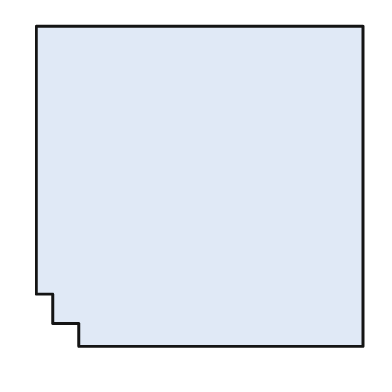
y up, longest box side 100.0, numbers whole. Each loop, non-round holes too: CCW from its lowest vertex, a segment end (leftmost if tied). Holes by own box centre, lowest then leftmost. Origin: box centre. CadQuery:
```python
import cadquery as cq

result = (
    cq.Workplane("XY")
    .moveTo(-37.0, -49.0)
    .lineTo(50.0, -49.0)
    .lineTo(50.0, 49.0)
    .lineTo(-50.0, 49.0)
    .lineTo(-50.0, -33.0)
    .lineTo(-45.0, -33.0)
    .lineTo(-45.0, -42.0)
    .lineTo(-37.0, -42.0)
    .close()
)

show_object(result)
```